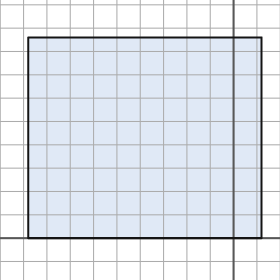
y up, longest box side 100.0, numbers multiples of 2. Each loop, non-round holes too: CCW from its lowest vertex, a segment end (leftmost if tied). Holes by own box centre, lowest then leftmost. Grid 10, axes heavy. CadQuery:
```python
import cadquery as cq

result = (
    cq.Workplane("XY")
    .moveTo(-88.0, 0.0)
    .lineTo(12.0, 0.0)
    .lineTo(12.0, 86.0)
    .lineTo(-88.0, 86.0)
    .close()
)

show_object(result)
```